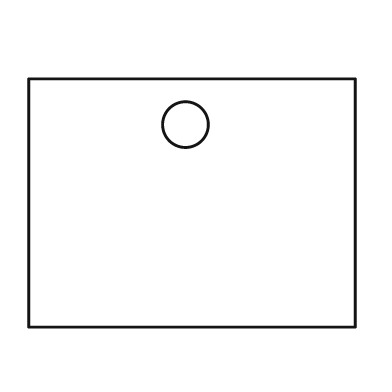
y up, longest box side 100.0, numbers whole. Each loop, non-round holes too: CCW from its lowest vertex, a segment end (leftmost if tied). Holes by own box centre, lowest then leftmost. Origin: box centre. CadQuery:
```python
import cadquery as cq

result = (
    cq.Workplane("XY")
    .moveTo(-50.0, -38.0)
    .lineTo(50.0, -38.0)
    .lineTo(50.0, 38.0)
    .lineTo(-50.0, 38.0)
    .close()
    .moveTo(-2.0, 24.0)
    .circle(7.0)
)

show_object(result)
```